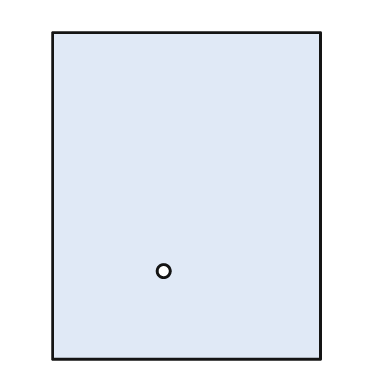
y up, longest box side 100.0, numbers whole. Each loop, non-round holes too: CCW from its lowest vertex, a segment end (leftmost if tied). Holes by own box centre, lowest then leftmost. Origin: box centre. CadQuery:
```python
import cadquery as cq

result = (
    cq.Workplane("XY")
    .moveTo(-41.0, -50.0)
    .lineTo(41.0, -50.0)
    .lineTo(41.0, 50.0)
    .lineTo(-41.0, 50.0)
    .close()
    .moveTo(-7.0, -23.0)
    .circle(2.0)
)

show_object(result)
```